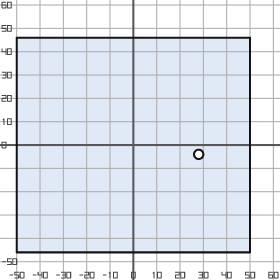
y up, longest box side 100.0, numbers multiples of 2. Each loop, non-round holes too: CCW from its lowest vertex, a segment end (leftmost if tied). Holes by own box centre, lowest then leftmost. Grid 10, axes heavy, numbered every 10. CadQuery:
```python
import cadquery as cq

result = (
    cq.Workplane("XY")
    .moveTo(-50.0, -46.0)
    .lineTo(50.0, -46.0)
    .lineTo(50.0, 46.0)
    .lineTo(-50.0, 46.0)
    .close()
    .moveTo(28.0, -4.0)
    .circle(2.0)
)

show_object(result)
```